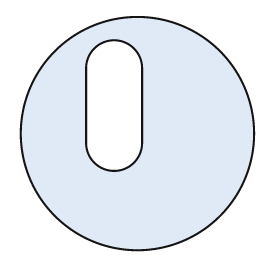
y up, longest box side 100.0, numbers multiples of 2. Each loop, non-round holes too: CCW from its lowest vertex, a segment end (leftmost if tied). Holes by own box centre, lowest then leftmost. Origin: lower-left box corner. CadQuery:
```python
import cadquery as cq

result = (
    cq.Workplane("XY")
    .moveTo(50.0, 50.0)
    .circle(50.0)
    .moveTo(28.0, 46.0)
    .threePointArc((40.0, 34.0), (52.0, 46.0))
    .lineTo(52.0, 78.0)
    .threePointArc((40.0, 90.0), (28.0, 78.0))
    .close()
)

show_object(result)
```